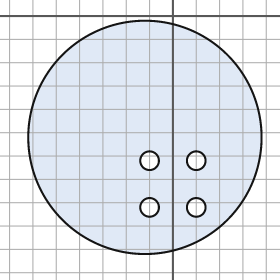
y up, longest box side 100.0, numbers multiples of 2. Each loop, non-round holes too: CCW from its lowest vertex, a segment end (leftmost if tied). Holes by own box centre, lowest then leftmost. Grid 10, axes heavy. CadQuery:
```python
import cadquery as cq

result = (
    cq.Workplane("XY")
    .moveTo(-12.0, -52.0)
    .circle(50.0)
    .moveTo(-10.0, -82.0)
    .circle(4.0)
    .moveTo(10.0, -82.0)
    .circle(4.0)
    .moveTo(-10.0, -62.0)
    .circle(4.0)
    .moveTo(10.0, -62.0)
    .circle(4.0)
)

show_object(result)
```